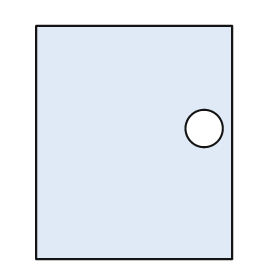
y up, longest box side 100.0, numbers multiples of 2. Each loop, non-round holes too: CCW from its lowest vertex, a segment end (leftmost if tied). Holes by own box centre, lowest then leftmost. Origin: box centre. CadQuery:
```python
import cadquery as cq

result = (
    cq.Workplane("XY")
    .moveTo(-42.0, -50.0)
    .lineTo(42.0, -50.0)
    .lineTo(42.0, 50.0)
    .lineTo(-42.0, 50.0)
    .close()
    .moveTo(30.0, 6.0)
    .circle(8.0)
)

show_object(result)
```